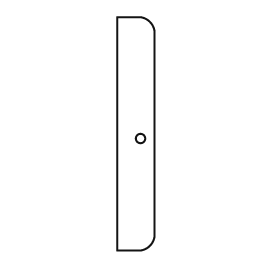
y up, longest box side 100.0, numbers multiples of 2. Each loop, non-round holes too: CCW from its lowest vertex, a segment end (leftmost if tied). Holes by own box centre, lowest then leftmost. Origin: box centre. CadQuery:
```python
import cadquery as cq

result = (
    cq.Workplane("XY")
    .moveTo(-8.0, -50.0)
    .lineTo(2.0, -50.0)
    .threePointArc((6.0, -48.0), (8.0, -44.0))
    .lineTo(8.0, 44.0)
    .threePointArc((6.0, 48.0), (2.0, 50.0))
    .lineTo(-8.0, 50.0)
    .close()
    .moveTo(2.0, -2.0)
    .circle(2.0)
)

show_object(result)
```